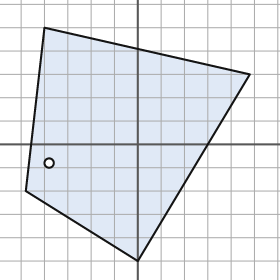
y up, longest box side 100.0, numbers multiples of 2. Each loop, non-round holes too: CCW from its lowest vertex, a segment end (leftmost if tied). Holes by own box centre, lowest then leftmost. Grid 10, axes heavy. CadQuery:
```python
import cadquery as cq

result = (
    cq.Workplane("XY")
    .moveTo(0.0, -50.0)
    .lineTo(48.0, 30.0)
    .lineTo(-40.0, 50.0)
    .lineTo(-48.0, -20.0)
    .close()
    .moveTo(-38.0, -8.0)
    .circle(2.0)
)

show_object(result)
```